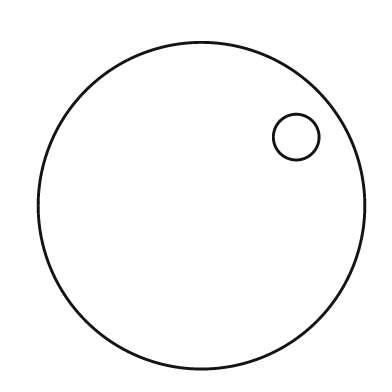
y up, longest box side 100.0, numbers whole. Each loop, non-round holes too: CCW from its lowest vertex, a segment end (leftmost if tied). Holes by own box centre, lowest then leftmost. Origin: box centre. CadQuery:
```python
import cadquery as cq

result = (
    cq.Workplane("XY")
    .moveTo(0.0, 0.0)
    .circle(50.0)
    .moveTo(29.0, 21.0)
    .circle(7.0)
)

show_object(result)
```